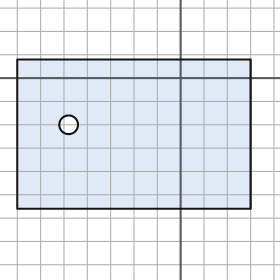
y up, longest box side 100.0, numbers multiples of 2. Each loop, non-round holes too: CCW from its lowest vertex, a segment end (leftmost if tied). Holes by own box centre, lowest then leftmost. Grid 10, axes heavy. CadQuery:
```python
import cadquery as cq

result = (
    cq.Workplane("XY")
    .moveTo(-70.0, -56.0)
    .lineTo(30.0, -56.0)
    .lineTo(30.0, 8.0)
    .lineTo(-70.0, 8.0)
    .close()
    .moveTo(-48.0, -20.0)
    .circle(4.0)
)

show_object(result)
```